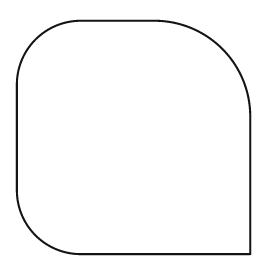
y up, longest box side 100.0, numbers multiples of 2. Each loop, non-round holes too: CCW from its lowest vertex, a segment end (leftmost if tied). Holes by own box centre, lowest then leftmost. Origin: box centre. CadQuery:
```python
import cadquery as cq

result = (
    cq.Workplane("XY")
    .moveTo(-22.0, -50.0)
    .lineTo(50.0, -50.0)
    .lineTo(50.0, 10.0)
    .threePointArc((38.0, 38.0), (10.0, 50.0))
    .lineTo(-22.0, 50.0)
    .threePointArc((-42.0, 42.0), (-50.0, 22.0))
    .lineTo(-50.0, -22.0)
    .threePointArc((-42.0, -42.0), (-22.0, -50.0))
    .close()
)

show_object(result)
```